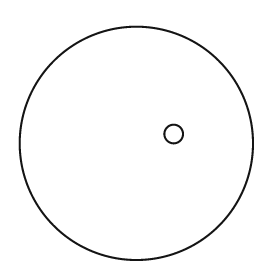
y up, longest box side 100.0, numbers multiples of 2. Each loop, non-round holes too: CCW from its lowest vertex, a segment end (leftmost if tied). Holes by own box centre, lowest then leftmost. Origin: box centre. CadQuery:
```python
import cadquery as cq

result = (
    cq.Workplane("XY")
    .moveTo(0.0, 0.0)
    .circle(50.0)
    .moveTo(16.0, 4.0)
    .circle(4.0)
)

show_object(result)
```